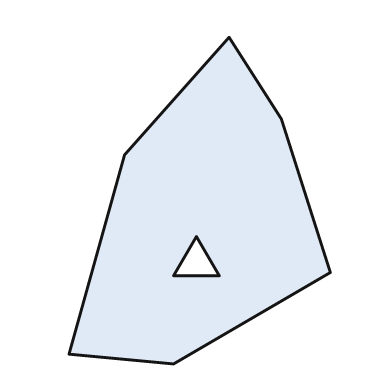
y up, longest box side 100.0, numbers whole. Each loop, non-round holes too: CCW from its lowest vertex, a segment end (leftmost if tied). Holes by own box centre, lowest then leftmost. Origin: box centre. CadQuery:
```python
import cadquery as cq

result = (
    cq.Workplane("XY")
    .moveTo(-8.0, -50.0)
    .lineTo(40.0, -22.0)
    .lineTo(25.0, 25.0)
    .lineTo(9.0, 50.0)
    .lineTo(-23.0, 14.0)
    .lineTo(-40.0, -47.0)
    .close()
    .moveTo(-8.0, -23.0)
    .lineTo(6.0, -23.0)
    .lineTo(-1.0, -11.0)
    .close()
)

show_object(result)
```